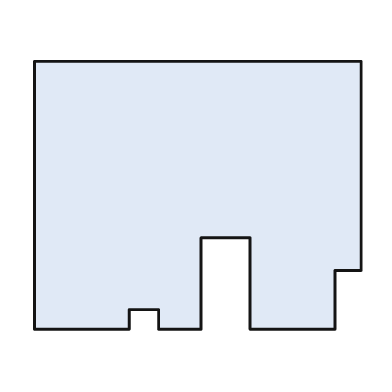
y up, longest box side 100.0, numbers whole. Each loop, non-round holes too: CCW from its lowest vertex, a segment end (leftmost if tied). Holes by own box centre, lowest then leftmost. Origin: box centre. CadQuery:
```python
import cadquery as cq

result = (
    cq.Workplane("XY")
    .moveTo(-50.0, -41.0)
    .lineTo(-21.0, -41.0)
    .lineTo(-21.0, -35.0)
    .lineTo(-12.0, -35.0)
    .lineTo(-12.0, -41.0)
    .lineTo(1.0, -41.0)
    .lineTo(1.0, -13.0)
    .lineTo(16.0, -13.0)
    .lineTo(16.0, -41.0)
    .lineTo(42.0, -41.0)
    .lineTo(42.0, -23.0)
    .lineTo(50.0, -23.0)
    .lineTo(50.0, 41.0)
    .lineTo(-50.0, 41.0)
    .close()
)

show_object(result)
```